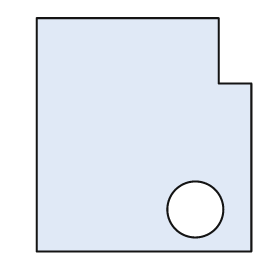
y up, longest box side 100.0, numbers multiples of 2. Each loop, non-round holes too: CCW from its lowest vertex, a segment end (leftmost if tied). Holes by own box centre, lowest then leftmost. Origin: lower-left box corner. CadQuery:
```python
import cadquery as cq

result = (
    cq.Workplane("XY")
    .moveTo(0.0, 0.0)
    .lineTo(92.0, 0.0)
    .lineTo(92.0, 72.0)
    .lineTo(78.0, 72.0)
    .lineTo(78.0, 100.0)
    .lineTo(0.0, 100.0)
    .close()
    .moveTo(68.0, 18.0)
    .circle(12.0)
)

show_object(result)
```